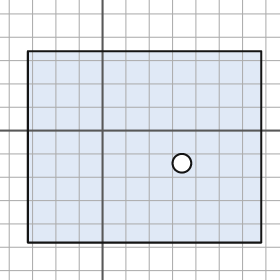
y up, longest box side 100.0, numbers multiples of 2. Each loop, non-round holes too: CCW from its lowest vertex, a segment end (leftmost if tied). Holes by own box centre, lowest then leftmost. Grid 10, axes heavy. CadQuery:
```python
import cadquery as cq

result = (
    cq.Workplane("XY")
    .moveTo(-32.0, -48.0)
    .lineTo(68.0, -48.0)
    .lineTo(68.0, 34.0)
    .lineTo(-32.0, 34.0)
    .close()
    .moveTo(34.0, -14.0)
    .circle(4.0)
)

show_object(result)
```